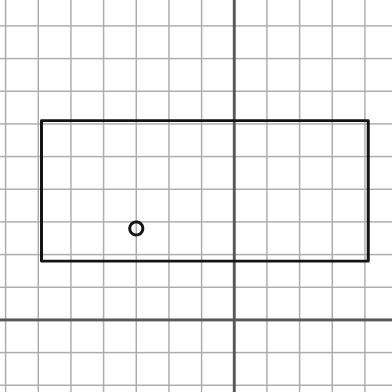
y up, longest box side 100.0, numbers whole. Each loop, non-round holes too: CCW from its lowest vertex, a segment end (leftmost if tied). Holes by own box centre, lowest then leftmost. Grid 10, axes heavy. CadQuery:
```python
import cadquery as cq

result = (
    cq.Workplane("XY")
    .moveTo(-59.0, 18.0)
    .lineTo(41.0, 18.0)
    .lineTo(41.0, 61.0)
    .lineTo(-59.0, 61.0)
    .close()
    .moveTo(-30.0, 28.0)
    .circle(2.0)
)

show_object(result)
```